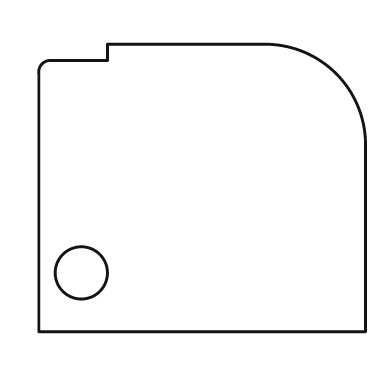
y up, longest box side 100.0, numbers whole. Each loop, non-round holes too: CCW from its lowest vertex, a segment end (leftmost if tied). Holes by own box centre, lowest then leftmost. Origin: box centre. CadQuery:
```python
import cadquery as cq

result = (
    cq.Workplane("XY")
    .moveTo(-50.0, -44.0)
    .lineTo(50.0, -44.0)
    .lineTo(50.0, 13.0)
    .threePointArc((41.0, 35.0), (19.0, 44.0))
    .lineTo(-29.0, 44.0)
    .lineTo(-29.0, 39.0)
    .lineTo(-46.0, 39.0)
    .threePointArc((-49.0, 38.0), (-50.0, 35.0))
    .close()
    .moveTo(-37.0, -26.0)
    .circle(8.0)
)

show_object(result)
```